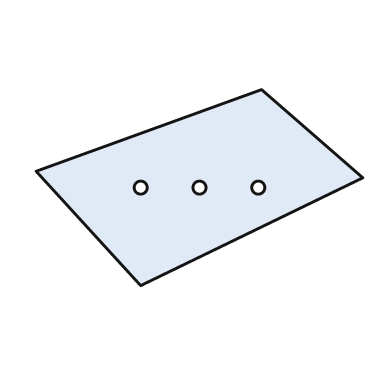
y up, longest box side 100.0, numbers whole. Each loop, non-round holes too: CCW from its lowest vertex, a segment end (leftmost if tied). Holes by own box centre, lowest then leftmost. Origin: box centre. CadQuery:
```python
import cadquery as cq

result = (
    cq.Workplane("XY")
    .moveTo(-18.0, -30.0)
    .lineTo(50.0, 3.0)
    .lineTo(19.0, 30.0)
    .lineTo(-50.0, 5.0)
    .close()
    .moveTo(-18.0, 0.0)
    .circle(2.0)
    .moveTo(0.0, 0.0)
    .circle(2.0)
    .moveTo(18.0, 0.0)
    .circle(2.0)
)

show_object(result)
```